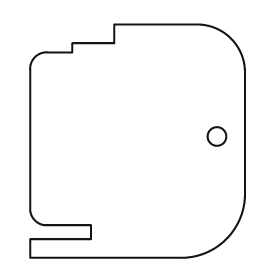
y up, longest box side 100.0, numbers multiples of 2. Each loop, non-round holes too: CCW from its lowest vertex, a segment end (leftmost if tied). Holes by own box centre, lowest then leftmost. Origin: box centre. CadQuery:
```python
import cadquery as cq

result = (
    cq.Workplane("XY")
    .moveTo(-46.0, -50.0)
    .lineTo(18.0, -50.0)
    .threePointArc((38.0, -42.0), (46.0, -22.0))
    .lineTo(46.0, 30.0)
    .threePointArc((40.0, 44.0), (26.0, 50.0))
    .lineTo(-10.0, 50.0)
    .lineTo(-10.0, 42.0)
    .lineTo(-28.0, 42.0)
    .lineTo(-28.0, 38.0)
    .lineTo(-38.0, 38.0)
    .threePointArc((-44.0, 36.0), (-46.0, 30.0))
    .lineTo(-46.0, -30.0)
    .threePointArc((-44.0, -34.0), (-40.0, -36.0))
    .lineTo(-20.0, -36.0)
    .lineTo(-20.0, -42.0)
    .lineTo(-46.0, -42.0)
    .close()
    .moveTo(34.0, 2.0)
    .circle(4.0)
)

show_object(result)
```